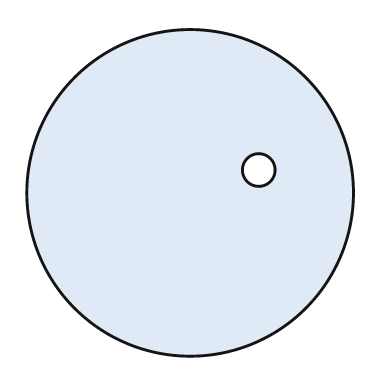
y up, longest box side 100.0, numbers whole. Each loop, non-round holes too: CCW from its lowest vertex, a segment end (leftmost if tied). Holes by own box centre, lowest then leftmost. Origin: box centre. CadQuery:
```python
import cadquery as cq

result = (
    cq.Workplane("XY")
    .moveTo(0.0, 0.0)
    .circle(50.0)
    .moveTo(21.0, 7.0)
    .circle(5.0)
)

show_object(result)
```